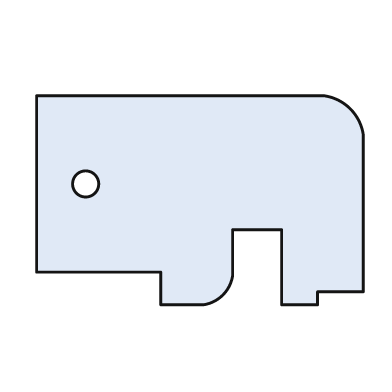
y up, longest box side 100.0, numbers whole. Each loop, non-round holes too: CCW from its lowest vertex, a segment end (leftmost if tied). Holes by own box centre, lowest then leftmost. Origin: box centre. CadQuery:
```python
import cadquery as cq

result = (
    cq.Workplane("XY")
    .moveTo(-12.0, -32.0)
    .lineTo(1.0, -32.0)
    .threePointArc((7.0, -29.0), (10.0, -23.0))
    .lineTo(10.0, -9.0)
    .lineTo(25.0, -9.0)
    .lineTo(25.0, -32.0)
    .lineTo(36.0, -32.0)
    .lineTo(36.0, -28.0)
    .lineTo(50.0, -28.0)
    .lineTo(50.0, 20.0)
    .threePointArc((46.0, 28.0), (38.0, 32.0))
    .lineTo(-50.0, 32.0)
    .lineTo(-50.0, -22.0)
    .lineTo(-12.0, -22.0)
    .close()
    .moveTo(-35.0, 5.0)
    .circle(4.0)
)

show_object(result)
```